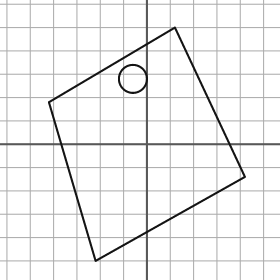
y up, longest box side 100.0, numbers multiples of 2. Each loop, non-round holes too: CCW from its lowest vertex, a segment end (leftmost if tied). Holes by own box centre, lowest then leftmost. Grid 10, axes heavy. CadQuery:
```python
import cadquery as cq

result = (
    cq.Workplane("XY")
    .moveTo(-22.0, -50.0)
    .lineTo(42.0, -14.0)
    .lineTo(12.0, 50.0)
    .lineTo(-42.0, 18.0)
    .close()
    .moveTo(-6.0, 28.0)
    .circle(6.0)
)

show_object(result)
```